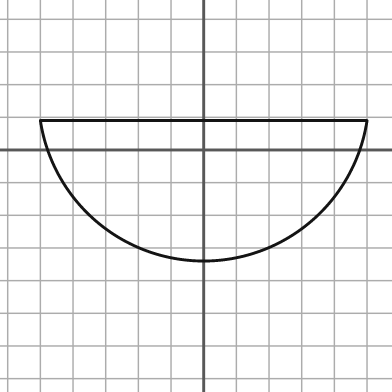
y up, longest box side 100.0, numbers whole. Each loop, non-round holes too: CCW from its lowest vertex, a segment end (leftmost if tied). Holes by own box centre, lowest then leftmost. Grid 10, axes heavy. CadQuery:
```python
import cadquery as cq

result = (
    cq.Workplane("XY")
    .moveTo(-50.0, 9.0)
    .threePointArc((0.0, -34.0), (50.0, 9.0))
    .close()
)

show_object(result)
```